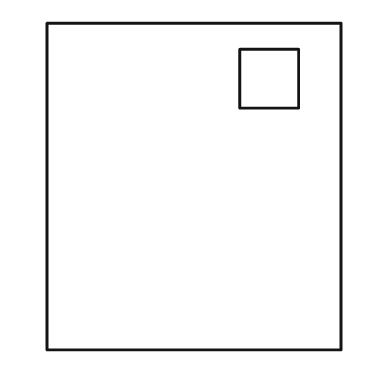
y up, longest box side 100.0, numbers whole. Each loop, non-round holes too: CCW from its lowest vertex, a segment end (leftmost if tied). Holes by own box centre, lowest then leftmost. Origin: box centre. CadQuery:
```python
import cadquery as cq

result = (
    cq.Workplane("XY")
    .moveTo(-45.0, -50.0)
    .lineTo(45.0, -50.0)
    .lineTo(45.0, 50.0)
    .lineTo(-45.0, 50.0)
    .close()
    .moveTo(14.0, 24.0)
    .lineTo(32.0, 24.0)
    .lineTo(32.0, 42.0)
    .lineTo(14.0, 42.0)
    .close()
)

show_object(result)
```